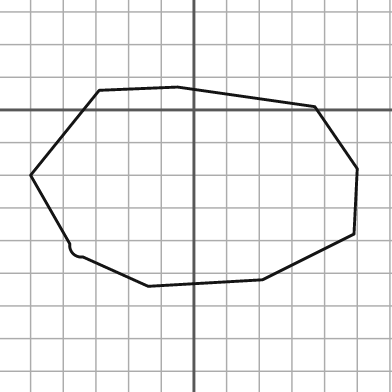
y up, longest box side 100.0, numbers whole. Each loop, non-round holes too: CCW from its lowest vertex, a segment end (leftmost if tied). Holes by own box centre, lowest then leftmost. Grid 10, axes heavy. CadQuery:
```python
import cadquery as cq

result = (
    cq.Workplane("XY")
    .moveTo(-14.0, -54.0)
    .lineTo(21.0, -52.0)
    .lineTo(49.0, -38.0)
    .lineTo(50.0, -18.0)
    .lineTo(37.0, 1.0)
    .lineTo(-5.0, 7.0)
    .lineTo(-29.0, 6.0)
    .lineTo(-50.0, -20.0)
    .lineTo(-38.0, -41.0)
    .threePointArc((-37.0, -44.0), (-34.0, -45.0))
    .close()
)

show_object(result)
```